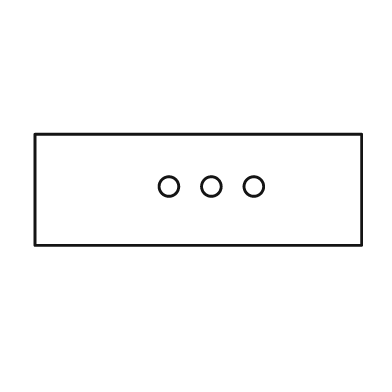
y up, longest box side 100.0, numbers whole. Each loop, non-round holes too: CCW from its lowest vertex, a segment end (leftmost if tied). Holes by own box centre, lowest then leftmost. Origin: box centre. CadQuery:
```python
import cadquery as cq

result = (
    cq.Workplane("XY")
    .moveTo(-50.0, -17.0)
    .lineTo(50.0, -17.0)
    .lineTo(50.0, 17.0)
    .lineTo(-50.0, 17.0)
    .close()
    .moveTo(-9.0, 1.0)
    .circle(3.0)
    .moveTo(4.0, 1.0)
    .circle(3.0)
    .moveTo(17.0, 1.0)
    .circle(3.0)
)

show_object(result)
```